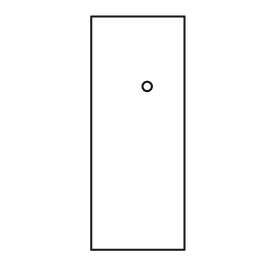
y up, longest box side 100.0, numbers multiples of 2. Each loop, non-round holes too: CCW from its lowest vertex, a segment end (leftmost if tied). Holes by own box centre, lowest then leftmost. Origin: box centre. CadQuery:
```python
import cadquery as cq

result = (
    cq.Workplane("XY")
    .moveTo(-20.0, -50.0)
    .lineTo(20.0, -50.0)
    .lineTo(20.0, 50.0)
    .lineTo(-20.0, 50.0)
    .close()
    .moveTo(4.0, 20.0)
    .circle(2.0)
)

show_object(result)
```